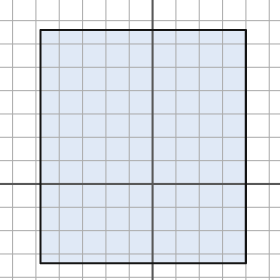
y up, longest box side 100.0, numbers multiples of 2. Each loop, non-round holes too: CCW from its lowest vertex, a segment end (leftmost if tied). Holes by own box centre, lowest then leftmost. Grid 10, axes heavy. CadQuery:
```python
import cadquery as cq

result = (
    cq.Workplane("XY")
    .moveTo(-48.0, -34.0)
    .lineTo(40.0, -34.0)
    .lineTo(40.0, 66.0)
    .lineTo(-48.0, 66.0)
    .close()
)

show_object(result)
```